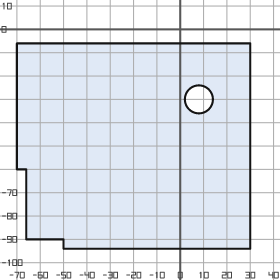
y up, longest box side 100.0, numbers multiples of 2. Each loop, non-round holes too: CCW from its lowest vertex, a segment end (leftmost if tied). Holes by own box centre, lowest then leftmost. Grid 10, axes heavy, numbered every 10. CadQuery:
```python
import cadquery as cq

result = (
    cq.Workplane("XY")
    .moveTo(-50.0, -94.0)
    .lineTo(30.0, -94.0)
    .lineTo(30.0, -6.0)
    .lineTo(-70.0, -6.0)
    .lineTo(-70.0, -60.0)
    .lineTo(-66.0, -60.0)
    .lineTo(-66.0, -90.0)
    .lineTo(-50.0, -90.0)
    .close()
    .moveTo(8.0, -30.0)
    .circle(6.0)
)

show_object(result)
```